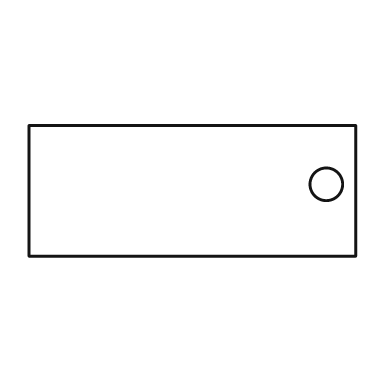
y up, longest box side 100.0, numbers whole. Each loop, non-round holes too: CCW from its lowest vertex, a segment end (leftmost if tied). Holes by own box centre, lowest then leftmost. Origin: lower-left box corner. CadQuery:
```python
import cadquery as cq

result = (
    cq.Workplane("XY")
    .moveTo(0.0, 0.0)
    .lineTo(100.0, 0.0)
    .lineTo(100.0, 40.0)
    .lineTo(0.0, 40.0)
    .close()
    .moveTo(91.0, 22.0)
    .circle(5.0)
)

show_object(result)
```